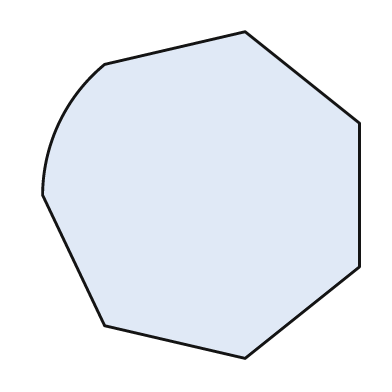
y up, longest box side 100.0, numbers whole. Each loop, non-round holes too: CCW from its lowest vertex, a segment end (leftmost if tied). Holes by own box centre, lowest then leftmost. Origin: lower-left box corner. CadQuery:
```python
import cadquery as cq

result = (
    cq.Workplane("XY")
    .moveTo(62.0, 0.0)
    .lineTo(97.0, 28.0)
    .lineTo(97.0, 72.0)
    .lineTo(62.0, 100.0)
    .lineTo(19.0, 90.0)
    .threePointArc((5.0, 72.0), (0.0, 50.0))
    .lineTo(19.0, 10.0)
    .close()
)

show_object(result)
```